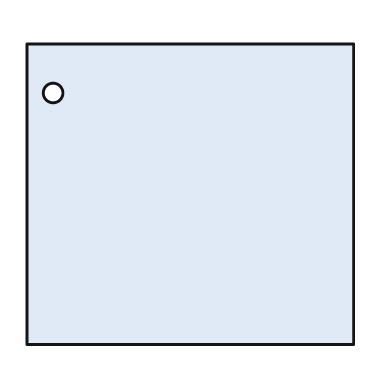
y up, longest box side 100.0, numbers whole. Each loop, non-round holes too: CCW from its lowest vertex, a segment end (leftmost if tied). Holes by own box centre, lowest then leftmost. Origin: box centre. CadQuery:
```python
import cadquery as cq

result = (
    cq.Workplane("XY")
    .moveTo(-50.0, -46.0)
    .lineTo(50.0, -46.0)
    .lineTo(50.0, 46.0)
    .lineTo(-50.0, 46.0)
    .close()
    .moveTo(-42.0, 31.0)
    .circle(3.0)
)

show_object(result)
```